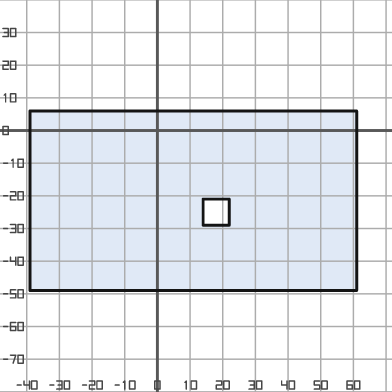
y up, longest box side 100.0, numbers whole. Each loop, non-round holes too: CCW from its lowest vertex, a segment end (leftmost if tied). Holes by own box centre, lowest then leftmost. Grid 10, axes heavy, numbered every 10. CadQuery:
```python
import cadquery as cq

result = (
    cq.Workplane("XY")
    .moveTo(-39.0, -49.0)
    .lineTo(61.0, -49.0)
    .lineTo(61.0, 6.0)
    .lineTo(-39.0, 6.0)
    .close()
    .moveTo(14.0, -29.0)
    .lineTo(22.0, -29.0)
    .lineTo(22.0, -21.0)
    .lineTo(14.0, -21.0)
    .close()
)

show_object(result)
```